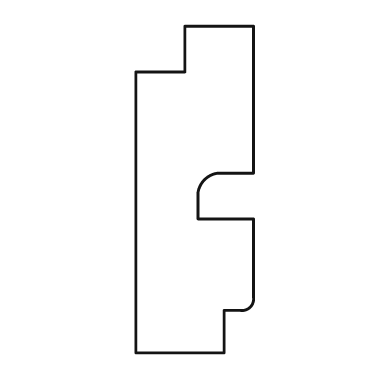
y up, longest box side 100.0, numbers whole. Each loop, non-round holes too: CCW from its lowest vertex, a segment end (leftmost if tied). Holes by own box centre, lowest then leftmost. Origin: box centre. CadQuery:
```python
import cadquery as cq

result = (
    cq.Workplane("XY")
    .moveTo(-18.0, -50.0)
    .lineTo(9.0, -50.0)
    .lineTo(9.0, -37.0)
    .lineTo(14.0, -37.0)
    .threePointArc((17.0, -36.0), (18.0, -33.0))
    .lineTo(18.0, -9.0)
    .lineTo(1.0, -9.0)
    .lineTo(1.0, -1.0)
    .threePointArc((3.0, 3.0), (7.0, 5.0))
    .lineTo(18.0, 5.0)
    .lineTo(18.0, 50.0)
    .lineTo(-3.0, 50.0)
    .lineTo(-3.0, 36.0)
    .lineTo(-18.0, 36.0)
    .close()
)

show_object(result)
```